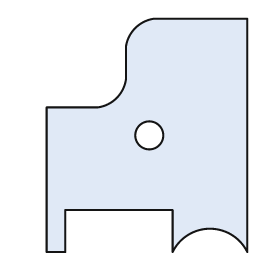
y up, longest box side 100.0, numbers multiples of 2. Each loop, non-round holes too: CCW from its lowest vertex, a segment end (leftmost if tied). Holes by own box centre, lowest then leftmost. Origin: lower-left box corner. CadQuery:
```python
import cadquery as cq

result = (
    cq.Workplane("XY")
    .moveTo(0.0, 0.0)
    .lineTo(8.0, 0.0)
    .lineTo(8.0, 18.0)
    .lineTo(54.0, 18.0)
    .lineTo(54.0, 0.0)
    .threePointArc((70.0, 10.0), (86.0, 0.0))
    .lineTo(86.0, 100.0)
    .lineTo(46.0, 100.0)
    .threePointArc((38.0, 96.0), (34.0, 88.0))
    .lineTo(34.0, 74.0)
    .threePointArc((30.0, 66.0), (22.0, 62.0))
    .lineTo(0.0, 62.0)
    .close()
    .moveTo(44.0, 50.0)
    .circle(6.0)
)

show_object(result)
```